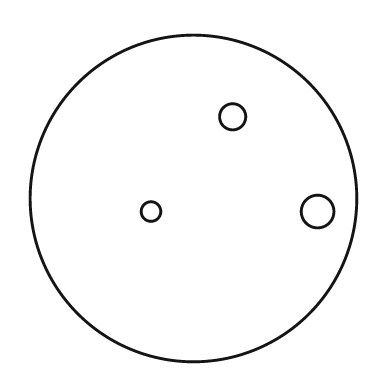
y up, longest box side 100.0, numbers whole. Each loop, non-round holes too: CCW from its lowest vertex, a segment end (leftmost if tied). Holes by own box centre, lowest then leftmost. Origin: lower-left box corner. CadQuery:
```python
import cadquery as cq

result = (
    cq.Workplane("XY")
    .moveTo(50.0, 50.0)
    .circle(50.0)
    .moveTo(37.0, 46.0)
    .circle(3.0)
    .moveTo(88.0, 46.0)
    .circle(5.0)
    .moveTo(62.0, 75.0)
    .circle(4.0)
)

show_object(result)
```